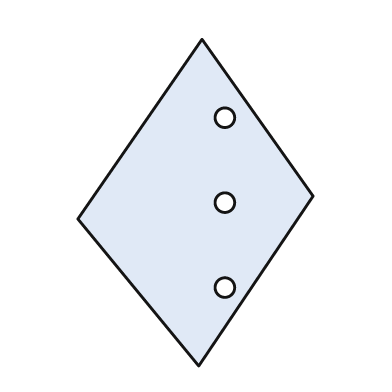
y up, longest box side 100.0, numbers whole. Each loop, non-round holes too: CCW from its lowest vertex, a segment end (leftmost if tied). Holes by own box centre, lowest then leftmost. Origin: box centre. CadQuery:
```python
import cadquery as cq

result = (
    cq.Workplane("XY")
    .moveTo(1.0, -50.0)
    .lineTo(36.0, 2.0)
    .lineTo(2.0, 50.0)
    .lineTo(-36.0, -5.0)
    .close()
    .moveTo(9.0, -26.0)
    .circle(3.0)
    .moveTo(9.0, 0.0)
    .circle(3.0)
    .moveTo(9.0, 26.0)
    .circle(3.0)
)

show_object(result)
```